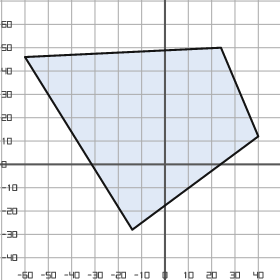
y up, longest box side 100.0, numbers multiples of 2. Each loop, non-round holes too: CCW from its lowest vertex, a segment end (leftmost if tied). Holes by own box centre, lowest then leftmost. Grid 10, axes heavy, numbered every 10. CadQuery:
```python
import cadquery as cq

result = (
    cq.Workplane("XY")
    .moveTo(-14.0, -28.0)
    .lineTo(40.0, 12.0)
    .lineTo(24.0, 50.0)
    .lineTo(-60.0, 46.0)
    .close()
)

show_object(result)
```